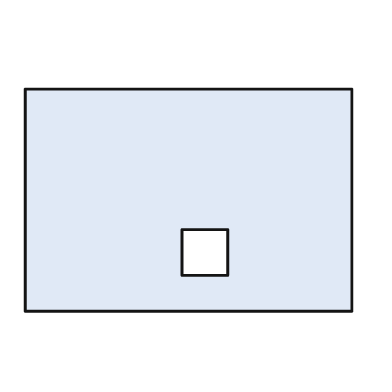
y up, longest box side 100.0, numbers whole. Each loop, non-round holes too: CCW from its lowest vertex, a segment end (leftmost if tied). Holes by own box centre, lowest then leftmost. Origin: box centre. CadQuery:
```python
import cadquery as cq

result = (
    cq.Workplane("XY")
    .moveTo(-50.0, -34.0)
    .lineTo(50.0, -34.0)
    .lineTo(50.0, 34.0)
    .lineTo(-50.0, 34.0)
    .close()
    .moveTo(-2.0, -23.0)
    .lineTo(12.0, -23.0)
    .lineTo(12.0, -9.0)
    .lineTo(-2.0, -9.0)
    .close()
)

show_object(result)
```